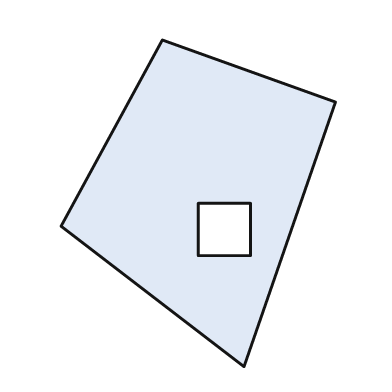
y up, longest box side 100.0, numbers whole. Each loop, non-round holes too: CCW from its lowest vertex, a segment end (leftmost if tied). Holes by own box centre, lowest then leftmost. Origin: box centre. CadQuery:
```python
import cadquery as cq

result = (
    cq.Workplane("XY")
    .moveTo(14.0, -50.0)
    .lineTo(42.0, 31.0)
    .lineTo(-11.0, 50.0)
    .lineTo(-42.0, -7.0)
    .close()
    .moveTo(0.0, -16.0)
    .lineTo(16.0, -16.0)
    .lineTo(16.0, 0.0)
    .lineTo(0.0, 0.0)
    .close()
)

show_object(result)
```